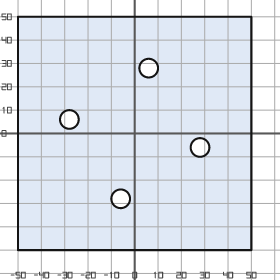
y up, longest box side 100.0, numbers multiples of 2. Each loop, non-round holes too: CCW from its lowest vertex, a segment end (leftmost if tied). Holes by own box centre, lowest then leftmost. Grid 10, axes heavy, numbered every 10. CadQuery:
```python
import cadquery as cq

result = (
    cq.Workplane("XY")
    .moveTo(-50.0, -50.0)
    .lineTo(50.0, -50.0)
    .lineTo(50.0, 50.0)
    .lineTo(-50.0, 50.0)
    .close()
    .moveTo(-6.0, -28.0)
    .circle(4.0)
    .moveTo(28.0, -6.0)
    .circle(4.0)
    .moveTo(-28.0, 6.0)
    .circle(4.0)
    .moveTo(6.0, 28.0)
    .circle(4.0)
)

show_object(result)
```